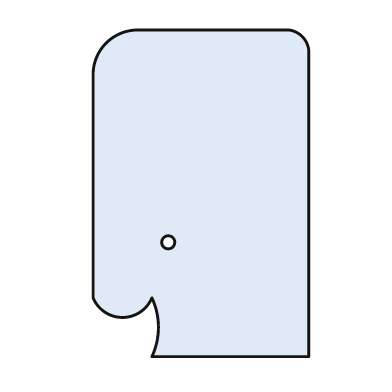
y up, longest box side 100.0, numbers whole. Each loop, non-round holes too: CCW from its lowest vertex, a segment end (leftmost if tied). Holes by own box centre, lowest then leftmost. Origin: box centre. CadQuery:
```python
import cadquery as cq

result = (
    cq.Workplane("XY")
    .moveTo(-15.0, -50.0)
    .lineTo(33.0, -50.0)
    .lineTo(33.0, 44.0)
    .threePointArc((31.0, 48.0), (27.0, 50.0))
    .lineTo(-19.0, 50.0)
    .threePointArc((-29.0, 46.0), (-33.0, 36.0))
    .lineTo(-33.0, -32.0)
    .threePointArc((-24.0, -38.0), (-15.0, -32.0))
    .threePointArc((-13.0, -41.0), (-15.0, -50.0))
    .close()
    .moveTo(-10.0, -15.0)
    .circle(2.0)
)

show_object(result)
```